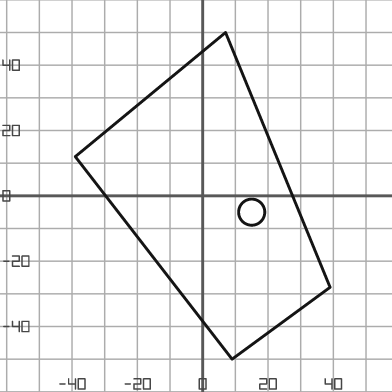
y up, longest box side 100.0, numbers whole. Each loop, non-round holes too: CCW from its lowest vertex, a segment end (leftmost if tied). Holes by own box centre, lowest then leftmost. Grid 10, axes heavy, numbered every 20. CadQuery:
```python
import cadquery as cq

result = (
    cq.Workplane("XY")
    .moveTo(9.0, -50.0)
    .lineTo(39.0, -28.0)
    .lineTo(7.0, 50.0)
    .lineTo(-39.0, 12.0)
    .close()
    .moveTo(15.0, -5.0)
    .circle(4.0)
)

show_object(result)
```